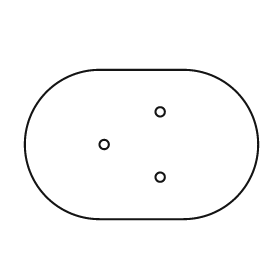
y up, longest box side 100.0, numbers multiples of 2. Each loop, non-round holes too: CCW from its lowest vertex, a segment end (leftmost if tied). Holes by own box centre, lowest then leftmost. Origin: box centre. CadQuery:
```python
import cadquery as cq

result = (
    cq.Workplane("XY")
    .moveTo(-18.0, -32.0)
    .lineTo(18.0, -32.0)
    .threePointArc((50.0, 0.0), (18.0, 32.0))
    .lineTo(-18.0, 32.0)
    .threePointArc((-50.0, 0.0), (-18.0, -32.0))
    .close()
    .moveTo(8.0, -14.0)
    .circle(2.0)
    .moveTo(-16.0, 0.0)
    .circle(2.0)
    .moveTo(8.0, 14.0)
    .circle(2.0)
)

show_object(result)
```